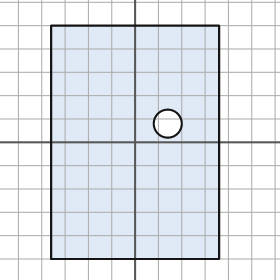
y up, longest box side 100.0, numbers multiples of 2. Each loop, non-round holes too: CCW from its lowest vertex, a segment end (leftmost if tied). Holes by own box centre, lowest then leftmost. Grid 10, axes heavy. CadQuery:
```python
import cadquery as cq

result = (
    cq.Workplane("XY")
    .moveTo(-36.0, -50.0)
    .lineTo(36.0, -50.0)
    .lineTo(36.0, 50.0)
    .lineTo(-36.0, 50.0)
    .close()
    .moveTo(14.0, 8.0)
    .circle(6.0)
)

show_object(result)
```